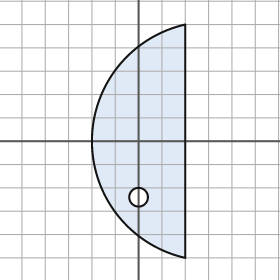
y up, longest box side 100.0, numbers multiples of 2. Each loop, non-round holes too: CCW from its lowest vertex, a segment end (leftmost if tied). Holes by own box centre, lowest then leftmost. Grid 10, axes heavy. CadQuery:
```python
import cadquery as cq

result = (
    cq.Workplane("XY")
    .moveTo(20.0, -50.0)
    .lineTo(20.0, 50.0)
    .threePointArc((-20.0, 0.0), (20.0, -50.0))
    .close()
    .moveTo(0.0, -24.0)
    .circle(4.0)
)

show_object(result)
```